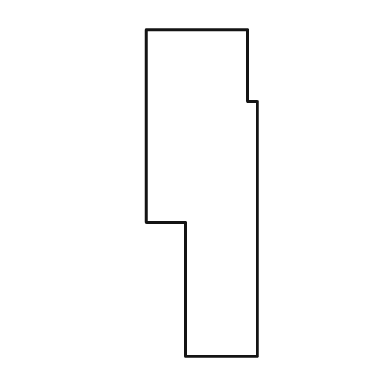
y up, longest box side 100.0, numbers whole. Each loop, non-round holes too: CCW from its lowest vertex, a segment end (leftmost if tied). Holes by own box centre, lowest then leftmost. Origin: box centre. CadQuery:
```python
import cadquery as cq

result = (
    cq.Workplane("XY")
    .moveTo(-5.0, -50.0)
    .lineTo(17.0, -50.0)
    .lineTo(17.0, 28.0)
    .lineTo(14.0, 28.0)
    .lineTo(14.0, 50.0)
    .lineTo(-17.0, 50.0)
    .lineTo(-17.0, -9.0)
    .lineTo(-5.0, -9.0)
    .close()
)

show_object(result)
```